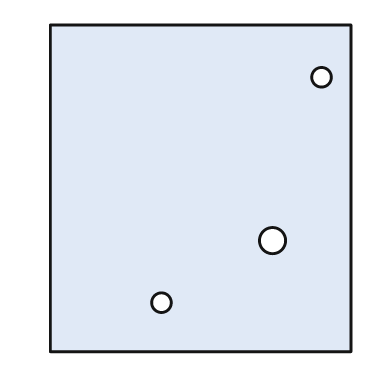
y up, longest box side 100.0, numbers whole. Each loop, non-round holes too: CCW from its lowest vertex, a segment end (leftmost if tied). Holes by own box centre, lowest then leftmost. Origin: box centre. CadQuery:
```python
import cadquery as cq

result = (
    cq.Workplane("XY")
    .moveTo(-46.0, -50.0)
    .lineTo(46.0, -50.0)
    .lineTo(46.0, 50.0)
    .lineTo(-46.0, 50.0)
    .close()
    .moveTo(-12.0, -35.0)
    .circle(3.0)
    .moveTo(22.0, -16.0)
    .circle(4.0)
    .moveTo(37.0, 34.0)
    .circle(3.0)
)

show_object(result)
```